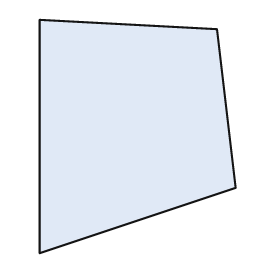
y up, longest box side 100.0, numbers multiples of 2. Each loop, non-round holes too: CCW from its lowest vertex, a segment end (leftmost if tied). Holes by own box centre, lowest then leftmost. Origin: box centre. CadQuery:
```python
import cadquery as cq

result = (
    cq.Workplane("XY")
    .moveTo(-42.0, -50.0)
    .lineTo(42.0, -22.0)
    .lineTo(34.0, 46.0)
    .lineTo(-42.0, 50.0)
    .close()
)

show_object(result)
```